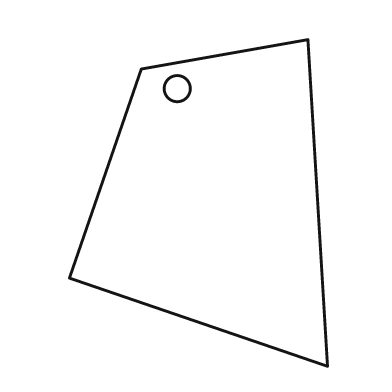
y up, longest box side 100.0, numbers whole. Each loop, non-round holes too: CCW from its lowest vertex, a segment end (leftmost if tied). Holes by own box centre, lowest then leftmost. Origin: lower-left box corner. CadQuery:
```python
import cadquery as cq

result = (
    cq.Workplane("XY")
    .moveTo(79.0, 0.0)
    .lineTo(73.0, 100.0)
    .lineTo(22.0, 91.0)
    .lineTo(0.0, 27.0)
    .close()
    .moveTo(33.0, 85.0)
    .circle(4.0)
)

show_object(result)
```